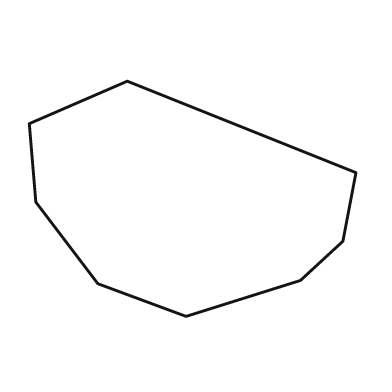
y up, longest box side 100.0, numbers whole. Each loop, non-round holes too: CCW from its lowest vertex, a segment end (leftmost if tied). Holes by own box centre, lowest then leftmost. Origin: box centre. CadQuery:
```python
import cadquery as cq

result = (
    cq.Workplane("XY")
    .moveTo(-2.0, -36.0)
    .lineTo(33.0, -25.0)
    .lineTo(46.0, -13.0)
    .lineTo(50.0, 8.0)
    .lineTo(-20.0, 36.0)
    .lineTo(-50.0, 23.0)
    .lineTo(-48.0, -1.0)
    .lineTo(-29.0, -26.0)
    .close()
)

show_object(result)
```